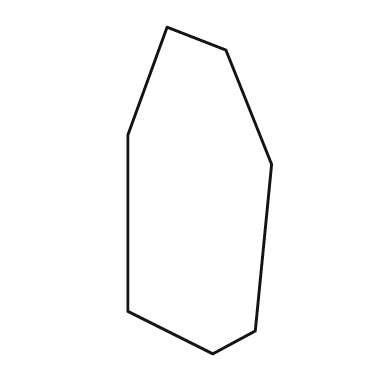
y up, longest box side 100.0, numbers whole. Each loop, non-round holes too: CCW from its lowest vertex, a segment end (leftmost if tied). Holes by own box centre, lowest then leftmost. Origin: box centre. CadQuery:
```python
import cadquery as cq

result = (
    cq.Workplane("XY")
    .moveTo(4.0, -50.0)
    .lineTo(17.0, -43.0)
    .lineTo(22.0, 8.0)
    .lineTo(8.0, 43.0)
    .lineTo(-10.0, 50.0)
    .lineTo(-22.0, 17.0)
    .lineTo(-22.0, -37.0)
    .close()
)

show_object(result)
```